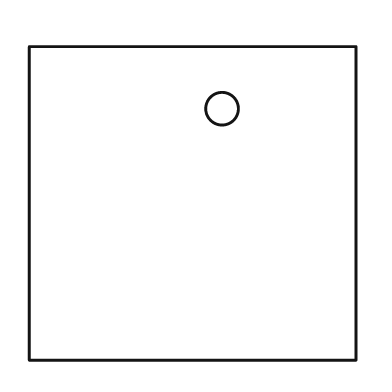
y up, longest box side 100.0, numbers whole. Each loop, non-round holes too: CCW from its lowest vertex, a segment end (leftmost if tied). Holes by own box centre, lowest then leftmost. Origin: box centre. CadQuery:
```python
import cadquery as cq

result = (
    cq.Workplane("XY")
    .moveTo(-50.0, -48.0)
    .lineTo(50.0, -48.0)
    .lineTo(50.0, 48.0)
    .lineTo(-50.0, 48.0)
    .close()
    .moveTo(9.0, 29.0)
    .circle(5.0)
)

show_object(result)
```